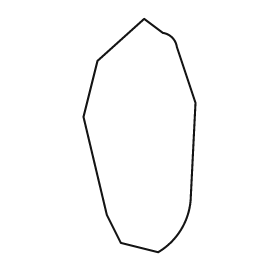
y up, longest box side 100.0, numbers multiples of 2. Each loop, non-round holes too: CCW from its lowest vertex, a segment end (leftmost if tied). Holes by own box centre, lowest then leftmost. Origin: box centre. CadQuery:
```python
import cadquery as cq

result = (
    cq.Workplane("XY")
    .moveTo(8.0, -50.0)
    .threePointArc((18.0, -40.0), (22.0, -26.0))
    .lineTo(24.0, 14.0)
    .lineTo(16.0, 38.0)
    .threePointArc((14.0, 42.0), (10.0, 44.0))
    .lineTo(2.0, 50.0)
    .lineTo(-18.0, 32.0)
    .lineTo(-24.0, 8.0)
    .lineTo(-14.0, -34.0)
    .lineTo(-8.0, -46.0)
    .close()
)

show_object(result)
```